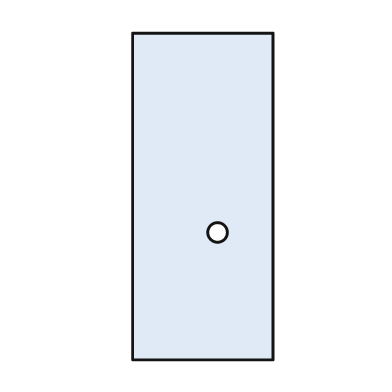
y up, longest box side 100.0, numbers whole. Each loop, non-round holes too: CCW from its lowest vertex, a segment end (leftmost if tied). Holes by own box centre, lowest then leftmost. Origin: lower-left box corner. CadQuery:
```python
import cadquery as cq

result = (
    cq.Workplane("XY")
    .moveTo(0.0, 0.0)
    .lineTo(43.0, 0.0)
    .lineTo(43.0, 100.0)
    .lineTo(0.0, 100.0)
    .close()
    .moveTo(26.0, 39.0)
    .circle(3.0)
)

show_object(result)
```